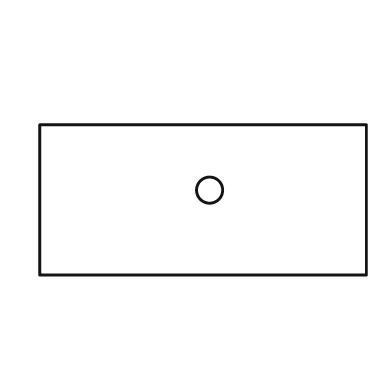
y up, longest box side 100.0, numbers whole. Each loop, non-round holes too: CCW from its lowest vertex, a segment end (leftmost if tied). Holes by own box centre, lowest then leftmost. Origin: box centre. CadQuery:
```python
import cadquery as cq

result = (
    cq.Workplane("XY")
    .moveTo(-50.0, -23.0)
    .lineTo(50.0, -23.0)
    .lineTo(50.0, 23.0)
    .lineTo(-50.0, 23.0)
    .close()
    .moveTo(2.0, 3.0)
    .circle(4.0)
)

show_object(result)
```